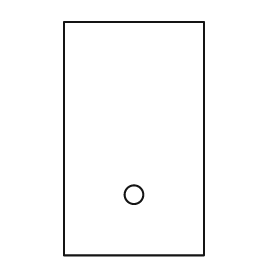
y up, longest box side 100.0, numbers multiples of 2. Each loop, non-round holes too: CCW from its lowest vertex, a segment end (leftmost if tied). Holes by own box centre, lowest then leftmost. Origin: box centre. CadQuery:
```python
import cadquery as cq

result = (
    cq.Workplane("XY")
    .moveTo(-30.0, -50.0)
    .lineTo(30.0, -50.0)
    .lineTo(30.0, 50.0)
    .lineTo(-30.0, 50.0)
    .close()
    .moveTo(0.0, -24.0)
    .circle(4.0)
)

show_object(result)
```